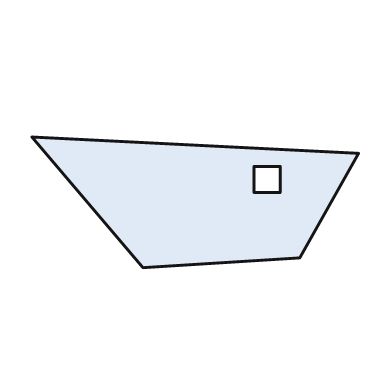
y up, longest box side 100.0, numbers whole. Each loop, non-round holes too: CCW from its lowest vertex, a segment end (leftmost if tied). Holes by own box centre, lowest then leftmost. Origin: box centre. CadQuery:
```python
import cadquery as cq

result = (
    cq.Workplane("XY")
    .moveTo(-16.0, -20.0)
    .lineTo(32.0, -17.0)
    .lineTo(50.0, 15.0)
    .lineTo(-50.0, 20.0)
    .close()
    .moveTo(18.0, 3.0)
    .lineTo(26.0, 3.0)
    .lineTo(26.0, 11.0)
    .lineTo(18.0, 11.0)
    .close()
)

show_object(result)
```